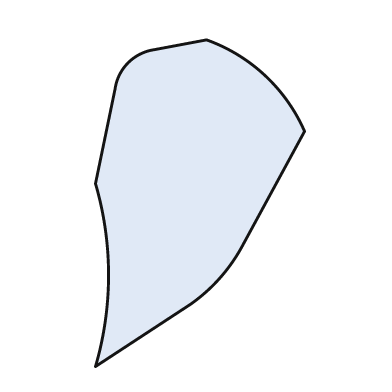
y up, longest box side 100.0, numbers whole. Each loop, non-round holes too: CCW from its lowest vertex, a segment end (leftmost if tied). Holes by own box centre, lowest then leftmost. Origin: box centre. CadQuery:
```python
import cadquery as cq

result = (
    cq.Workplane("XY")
    .moveTo(-32.0, -50.0)
    .lineTo(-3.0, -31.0)
    .threePointArc((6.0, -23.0), (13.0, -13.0))
    .lineTo(32.0, 22.0)
    .threePointArc((20.0, 39.0), (2.0, 50.0))
    .lineTo(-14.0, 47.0)
    .threePointArc((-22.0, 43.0), (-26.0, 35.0))
    .lineTo(-32.0, 6.0)
    .threePointArc((-28.0, -22.0), (-32.0, -50.0))
    .close()
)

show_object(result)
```